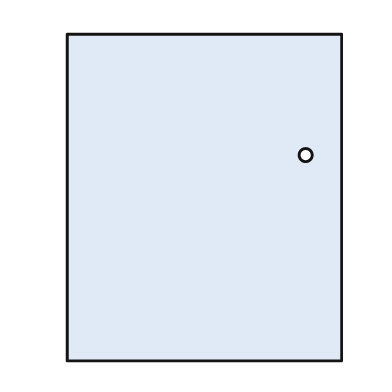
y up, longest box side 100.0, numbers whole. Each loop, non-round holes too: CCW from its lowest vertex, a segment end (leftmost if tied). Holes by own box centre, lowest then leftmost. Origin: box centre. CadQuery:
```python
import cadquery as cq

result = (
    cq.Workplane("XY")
    .moveTo(-42.0, -50.0)
    .lineTo(42.0, -50.0)
    .lineTo(42.0, 50.0)
    .lineTo(-42.0, 50.0)
    .close()
    .moveTo(31.0, 13.0)
    .circle(2.0)
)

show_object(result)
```